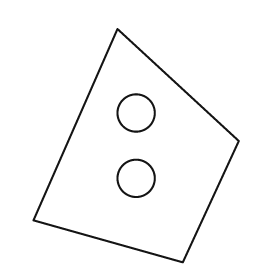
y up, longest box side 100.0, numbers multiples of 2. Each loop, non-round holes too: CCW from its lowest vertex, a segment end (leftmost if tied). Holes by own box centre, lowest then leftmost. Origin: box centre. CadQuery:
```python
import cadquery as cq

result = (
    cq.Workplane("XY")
    .moveTo(20.0, -50.0)
    .lineTo(44.0, 2.0)
    .lineTo(-8.0, 50.0)
    .lineTo(-44.0, -32.0)
    .close()
    .moveTo(0.0, -14.0)
    .circle(8.0)
    .moveTo(0.0, 14.0)
    .circle(8.0)
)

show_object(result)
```